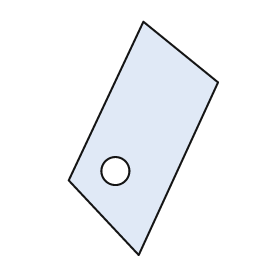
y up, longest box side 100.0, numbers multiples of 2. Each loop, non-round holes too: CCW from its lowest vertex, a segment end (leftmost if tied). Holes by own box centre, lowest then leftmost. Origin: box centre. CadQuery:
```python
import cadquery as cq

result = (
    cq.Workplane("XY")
    .moveTo(-2.0, -50.0)
    .lineTo(32.0, 24.0)
    .lineTo(0.0, 50.0)
    .lineTo(-32.0, -18.0)
    .close()
    .moveTo(-12.0, -14.0)
    .circle(6.0)
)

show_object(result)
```